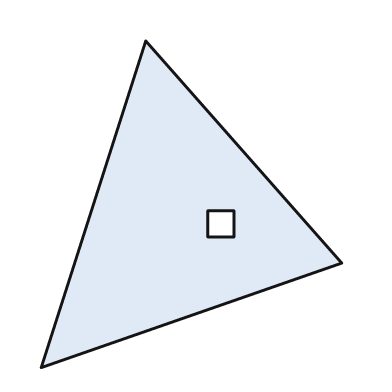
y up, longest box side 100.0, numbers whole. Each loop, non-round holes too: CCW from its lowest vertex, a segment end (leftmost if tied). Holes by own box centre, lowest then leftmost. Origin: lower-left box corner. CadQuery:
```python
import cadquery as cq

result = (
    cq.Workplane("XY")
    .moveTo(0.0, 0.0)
    .lineTo(92.0, 32.0)
    .lineTo(32.0, 100.0)
    .close()
    .moveTo(51.0, 40.0)
    .lineTo(59.0, 40.0)
    .lineTo(59.0, 48.0)
    .lineTo(51.0, 48.0)
    .close()
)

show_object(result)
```